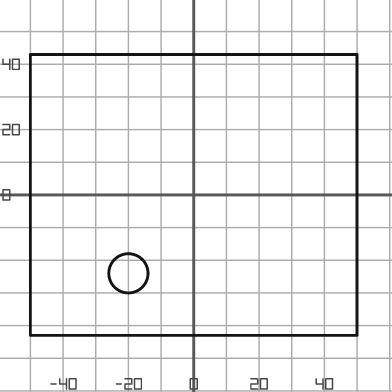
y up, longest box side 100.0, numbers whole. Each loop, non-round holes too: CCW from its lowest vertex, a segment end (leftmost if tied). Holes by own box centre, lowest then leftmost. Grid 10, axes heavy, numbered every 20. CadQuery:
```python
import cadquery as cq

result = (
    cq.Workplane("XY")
    .moveTo(-50.0, -43.0)
    .lineTo(50.0, -43.0)
    .lineTo(50.0, 43.0)
    .lineTo(-50.0, 43.0)
    .close()
    .moveTo(-20.0, -24.0)
    .circle(6.0)
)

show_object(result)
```